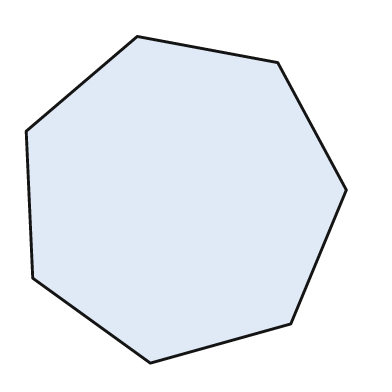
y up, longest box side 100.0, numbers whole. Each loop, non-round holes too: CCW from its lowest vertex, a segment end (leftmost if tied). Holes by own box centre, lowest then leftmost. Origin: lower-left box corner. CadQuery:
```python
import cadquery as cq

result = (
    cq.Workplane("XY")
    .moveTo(38.0, 0.0)
    .lineTo(81.0, 12.0)
    .lineTo(98.0, 53.0)
    .lineTo(77.0, 92.0)
    .lineTo(34.0, 100.0)
    .lineTo(0.0, 71.0)
    .lineTo(2.0, 26.0)
    .close()
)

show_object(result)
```